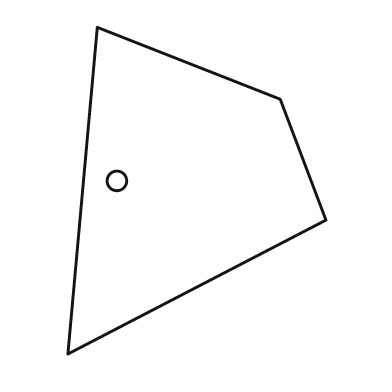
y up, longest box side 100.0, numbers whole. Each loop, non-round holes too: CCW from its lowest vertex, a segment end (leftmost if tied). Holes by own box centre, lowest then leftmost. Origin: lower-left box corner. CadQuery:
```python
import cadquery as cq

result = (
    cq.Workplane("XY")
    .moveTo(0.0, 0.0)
    .lineTo(79.0, 41.0)
    .lineTo(65.0, 78.0)
    .lineTo(9.0, 100.0)
    .close()
    .moveTo(15.0, 53.0)
    .circle(3.0)
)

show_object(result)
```